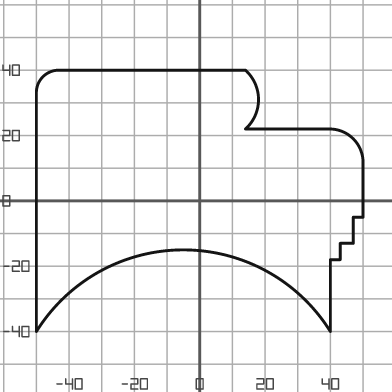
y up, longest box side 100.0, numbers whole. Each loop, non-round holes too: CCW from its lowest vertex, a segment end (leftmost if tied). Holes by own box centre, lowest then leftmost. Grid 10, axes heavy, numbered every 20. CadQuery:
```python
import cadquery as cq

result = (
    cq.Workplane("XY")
    .moveTo(-50.0, -40.0)
    .threePointArc((-5.0, -15.0), (40.0, -40.0))
    .lineTo(40.0, -18.0)
    .lineTo(43.0, -18.0)
    .lineTo(43.0, -13.0)
    .lineTo(47.0, -13.0)
    .lineTo(47.0, -5.0)
    .lineTo(50.0, -5.0)
    .lineTo(50.0, 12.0)
    .threePointArc((47.0, 19.0), (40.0, 22.0))
    .lineTo(14.0, 22.0)
    .threePointArc((18.0, 31.0), (14.0, 40.0))
    .lineTo(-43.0, 40.0)
    .threePointArc((-48.0, 38.0), (-50.0, 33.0))
    .close()
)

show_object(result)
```